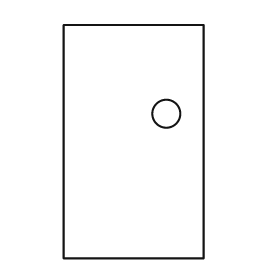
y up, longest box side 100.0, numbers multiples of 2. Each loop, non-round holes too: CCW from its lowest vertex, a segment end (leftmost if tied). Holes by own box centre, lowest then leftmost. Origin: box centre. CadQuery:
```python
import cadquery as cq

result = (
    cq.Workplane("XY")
    .moveTo(-30.0, -50.0)
    .lineTo(30.0, -50.0)
    .lineTo(30.0, 50.0)
    .lineTo(-30.0, 50.0)
    .close()
    .moveTo(14.0, 12.0)
    .circle(6.0)
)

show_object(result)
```